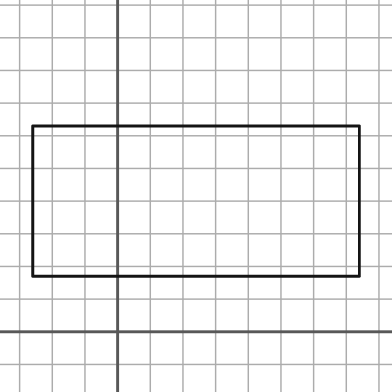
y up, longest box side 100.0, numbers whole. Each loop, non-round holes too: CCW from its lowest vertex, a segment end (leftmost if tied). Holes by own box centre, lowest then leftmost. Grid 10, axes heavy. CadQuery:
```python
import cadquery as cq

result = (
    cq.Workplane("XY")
    .moveTo(-26.0, 17.0)
    .lineTo(74.0, 17.0)
    .lineTo(74.0, 63.0)
    .lineTo(-26.0, 63.0)
    .close()
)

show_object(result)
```